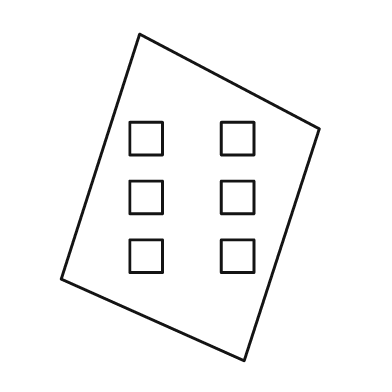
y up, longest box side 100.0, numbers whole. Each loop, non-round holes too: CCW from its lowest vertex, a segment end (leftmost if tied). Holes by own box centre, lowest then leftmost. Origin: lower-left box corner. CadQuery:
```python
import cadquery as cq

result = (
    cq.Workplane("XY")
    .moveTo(56.0, 0.0)
    .lineTo(79.0, 71.0)
    .lineTo(24.0, 100.0)
    .lineTo(0.0, 25.0)
    .close()
    .moveTo(21.0, 27.0)
    .lineTo(31.0, 27.0)
    .lineTo(31.0, 37.0)
    .lineTo(21.0, 37.0)
    .close()
    .moveTo(49.0, 27.0)
    .lineTo(59.0, 27.0)
    .lineTo(59.0, 37.0)
    .lineTo(49.0, 37.0)
    .close()
    .moveTo(21.0, 45.0)
    .lineTo(31.0, 45.0)
    .lineTo(31.0, 55.0)
    .lineTo(21.0, 55.0)
    .close()
    .moveTo(49.0, 45.0)
    .lineTo(59.0, 45.0)
    .lineTo(59.0, 55.0)
    .lineTo(49.0, 55.0)
    .close()
    .moveTo(21.0, 63.0)
    .lineTo(31.0, 63.0)
    .lineTo(31.0, 73.0)
    .lineTo(21.0, 73.0)
    .close()
    .moveTo(49.0, 63.0)
    .lineTo(59.0, 63.0)
    .lineTo(59.0, 73.0)
    .lineTo(49.0, 73.0)
    .close()
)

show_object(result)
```